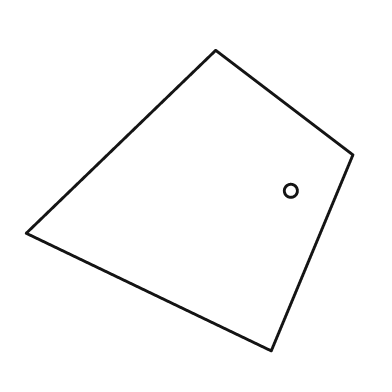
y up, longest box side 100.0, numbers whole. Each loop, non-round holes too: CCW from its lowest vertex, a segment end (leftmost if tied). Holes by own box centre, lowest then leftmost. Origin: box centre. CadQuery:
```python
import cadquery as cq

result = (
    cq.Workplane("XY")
    .moveTo(25.0, -46.0)
    .lineTo(50.0, 14.0)
    .lineTo(8.0, 46.0)
    .lineTo(-50.0, -10.0)
    .close()
    .moveTo(31.0, 3.0)
    .circle(2.0)
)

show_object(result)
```